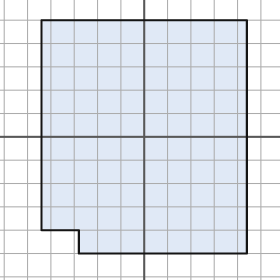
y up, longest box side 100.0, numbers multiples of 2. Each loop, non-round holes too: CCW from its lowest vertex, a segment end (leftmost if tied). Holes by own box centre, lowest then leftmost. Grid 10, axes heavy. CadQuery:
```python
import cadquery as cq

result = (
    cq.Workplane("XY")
    .moveTo(-28.0, -50.0)
    .lineTo(44.0, -50.0)
    .lineTo(44.0, 50.0)
    .lineTo(-44.0, 50.0)
    .lineTo(-44.0, -40.0)
    .lineTo(-28.0, -40.0)
    .close()
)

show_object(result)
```